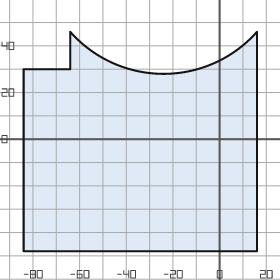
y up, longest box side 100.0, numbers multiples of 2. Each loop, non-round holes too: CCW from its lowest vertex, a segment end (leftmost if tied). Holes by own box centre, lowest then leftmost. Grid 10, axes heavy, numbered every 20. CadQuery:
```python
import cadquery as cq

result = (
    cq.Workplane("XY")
    .moveTo(-84.0, -48.0)
    .lineTo(16.0, -48.0)
    .lineTo(16.0, 46.0)
    .threePointArc((-24.0, 28.0), (-64.0, 46.0))
    .lineTo(-64.0, 30.0)
    .lineTo(-84.0, 30.0)
    .close()
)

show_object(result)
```